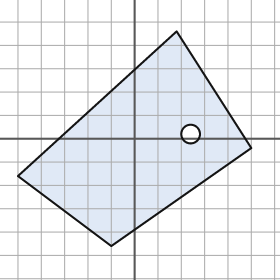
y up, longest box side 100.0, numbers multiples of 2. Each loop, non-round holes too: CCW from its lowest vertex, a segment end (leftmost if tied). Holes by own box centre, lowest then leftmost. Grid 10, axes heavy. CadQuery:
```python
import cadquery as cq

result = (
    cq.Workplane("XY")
    .moveTo(-10.0, -46.0)
    .lineTo(50.0, -4.0)
    .lineTo(18.0, 46.0)
    .lineTo(-50.0, -16.0)
    .close()
    .moveTo(24.0, 2.0)
    .circle(4.0)
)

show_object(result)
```